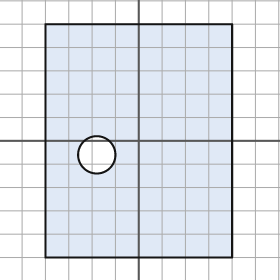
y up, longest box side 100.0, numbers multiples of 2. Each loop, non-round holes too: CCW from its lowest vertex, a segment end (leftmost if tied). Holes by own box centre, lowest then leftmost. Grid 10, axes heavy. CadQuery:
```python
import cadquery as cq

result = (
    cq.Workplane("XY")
    .moveTo(-40.0, -50.0)
    .lineTo(40.0, -50.0)
    .lineTo(40.0, 50.0)
    .lineTo(-40.0, 50.0)
    .close()
    .moveTo(-18.0, -6.0)
    .circle(8.0)
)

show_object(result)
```